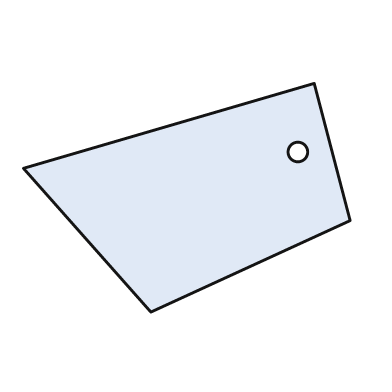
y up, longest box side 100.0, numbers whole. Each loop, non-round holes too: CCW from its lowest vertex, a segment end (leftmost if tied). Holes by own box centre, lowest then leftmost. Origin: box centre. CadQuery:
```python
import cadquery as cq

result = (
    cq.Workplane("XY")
    .moveTo(-11.0, -35.0)
    .lineTo(50.0, -7.0)
    .lineTo(39.0, 35.0)
    .lineTo(-50.0, 9.0)
    .close()
    .moveTo(34.0, 14.0)
    .circle(3.0)
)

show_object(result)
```